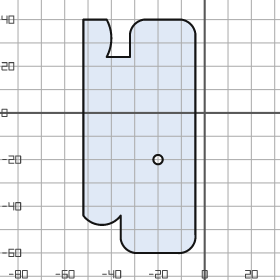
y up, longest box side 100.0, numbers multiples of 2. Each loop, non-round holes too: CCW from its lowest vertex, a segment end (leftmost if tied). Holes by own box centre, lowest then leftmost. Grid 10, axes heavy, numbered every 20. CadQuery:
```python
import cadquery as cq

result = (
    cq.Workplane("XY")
    .moveTo(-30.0, -60.0)
    .lineTo(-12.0, -60.0)
    .threePointArc((-6.0, -58.0), (-4.0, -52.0))
    .lineTo(-4.0, 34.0)
    .threePointArc((-6.0, 38.0), (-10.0, 40.0))
    .lineTo(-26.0, 40.0)
    .threePointArc((-30.0, 38.0), (-32.0, 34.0))
    .lineTo(-32.0, 24.0)
    .lineTo(-42.0, 24.0)
    .threePointArc((-40.0, 32.0), (-42.0, 40.0))
    .lineTo(-52.0, 40.0)
    .lineTo(-52.0, -44.0)
    .threePointArc((-44.0, -48.0), (-36.0, -44.0))
    .lineTo(-36.0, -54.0)
    .threePointArc((-34.0, -58.0), (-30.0, -60.0))
    .close()
    .moveTo(-20.0, -20.0)
    .circle(2.0)
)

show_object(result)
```